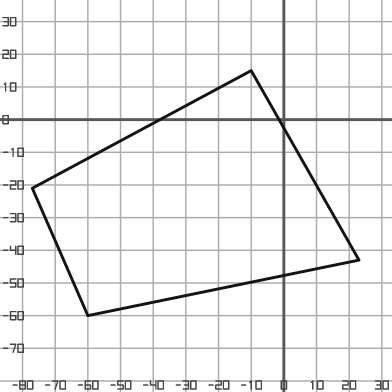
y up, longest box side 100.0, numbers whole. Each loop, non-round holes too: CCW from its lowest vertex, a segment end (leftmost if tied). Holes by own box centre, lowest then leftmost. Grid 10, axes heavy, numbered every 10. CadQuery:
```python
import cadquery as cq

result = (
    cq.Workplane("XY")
    .moveTo(-60.0, -60.0)
    .lineTo(23.0, -43.0)
    .lineTo(-10.0, 15.0)
    .lineTo(-77.0, -21.0)
    .close()
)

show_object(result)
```